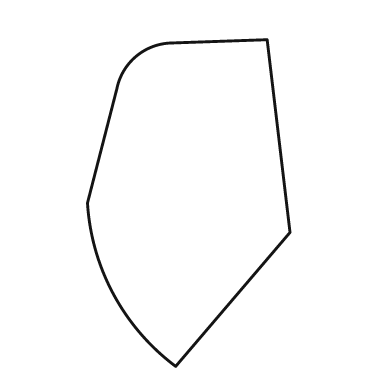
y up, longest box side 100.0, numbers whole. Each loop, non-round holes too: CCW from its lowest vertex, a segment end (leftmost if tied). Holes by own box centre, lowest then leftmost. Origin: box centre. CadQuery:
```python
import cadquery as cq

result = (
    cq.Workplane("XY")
    .moveTo(-4.0, -50.0)
    .lineTo(31.0, -9.0)
    .lineTo(24.0, 50.0)
    .lineTo(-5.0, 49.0)
    .threePointArc((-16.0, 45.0), (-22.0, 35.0))
    .lineTo(-31.0, 0.0)
    .threePointArc((-23.0, -28.0), (-4.0, -50.0))
    .close()
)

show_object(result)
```